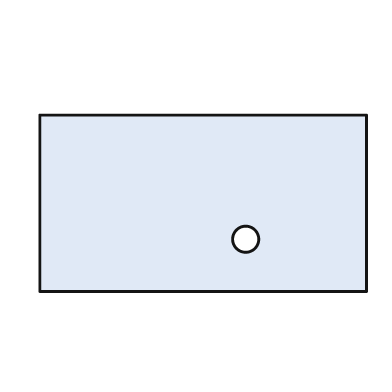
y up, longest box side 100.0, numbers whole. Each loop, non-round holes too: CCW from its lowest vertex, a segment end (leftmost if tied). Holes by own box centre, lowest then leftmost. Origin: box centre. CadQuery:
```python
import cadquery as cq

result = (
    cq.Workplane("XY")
    .moveTo(-50.0, -27.0)
    .lineTo(50.0, -27.0)
    .lineTo(50.0, 27.0)
    .lineTo(-50.0, 27.0)
    .close()
    .moveTo(13.0, -11.0)
    .circle(4.0)
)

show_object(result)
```